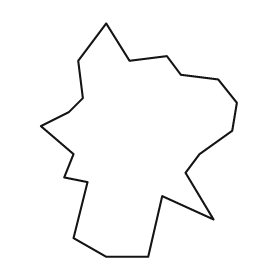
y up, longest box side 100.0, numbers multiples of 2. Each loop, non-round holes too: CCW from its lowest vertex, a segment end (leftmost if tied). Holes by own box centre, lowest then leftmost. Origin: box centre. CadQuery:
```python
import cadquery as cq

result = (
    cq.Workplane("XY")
    .moveTo(-14.0, -50.0)
    .lineTo(4.0, -50.0)
    .lineTo(10.0, -24.0)
    .lineTo(32.0, -34.0)
    .lineTo(20.0, -14.0)
    .lineTo(26.0, -6.0)
    .lineTo(40.0, 4.0)
    .lineTo(42.0, 16.0)
    .lineTo(34.0, 26.0)
    .lineTo(18.0, 28.0)
    .lineTo(12.0, 36.0)
    .lineTo(-4.0, 34.0)
    .lineTo(-14.0, 50.0)
    .lineTo(-26.0, 34.0)
    .lineTo(-24.0, 18.0)
    .lineTo(-30.0, 12.0)
    .lineTo(-42.0, 6.0)
    .lineTo(-28.0, -6.0)
    .lineTo(-32.0, -16.0)
    .lineTo(-22.0, -18.0)
    .lineTo(-28.0, -42.0)
    .close()
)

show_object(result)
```